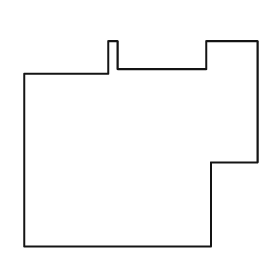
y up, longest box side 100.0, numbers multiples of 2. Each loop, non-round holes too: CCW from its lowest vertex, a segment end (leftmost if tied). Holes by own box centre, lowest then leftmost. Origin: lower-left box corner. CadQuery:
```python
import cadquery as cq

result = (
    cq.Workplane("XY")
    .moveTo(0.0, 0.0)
    .lineTo(80.0, 0.0)
    .lineTo(80.0, 36.0)
    .lineTo(100.0, 36.0)
    .lineTo(100.0, 88.0)
    .lineTo(78.0, 88.0)
    .lineTo(78.0, 76.0)
    .lineTo(40.0, 76.0)
    .lineTo(40.0, 88.0)
    .lineTo(36.0, 88.0)
    .lineTo(36.0, 74.0)
    .lineTo(0.0, 74.0)
    .close()
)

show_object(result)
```